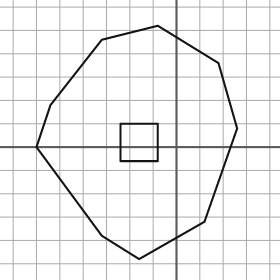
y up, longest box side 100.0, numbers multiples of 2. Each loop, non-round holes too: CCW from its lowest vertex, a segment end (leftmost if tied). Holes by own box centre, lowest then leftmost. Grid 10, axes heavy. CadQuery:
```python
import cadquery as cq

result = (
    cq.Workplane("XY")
    .moveTo(-16.0, -48.0)
    .lineTo(12.0, -32.0)
    .lineTo(26.0, 8.0)
    .lineTo(18.0, 36.0)
    .lineTo(-8.0, 52.0)
    .lineTo(-32.0, 46.0)
    .lineTo(-54.0, 18.0)
    .lineTo(-60.0, 0.0)
    .lineTo(-32.0, -38.0)
    .close()
    .moveTo(-24.0, -6.0)
    .lineTo(-8.0, -6.0)
    .lineTo(-8.0, 10.0)
    .lineTo(-24.0, 10.0)
    .close()
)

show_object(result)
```